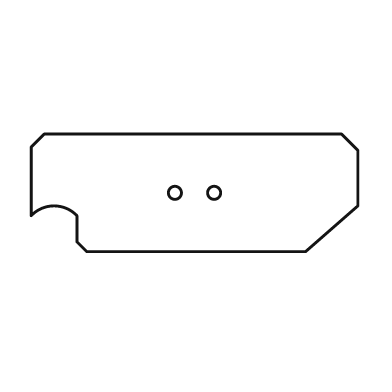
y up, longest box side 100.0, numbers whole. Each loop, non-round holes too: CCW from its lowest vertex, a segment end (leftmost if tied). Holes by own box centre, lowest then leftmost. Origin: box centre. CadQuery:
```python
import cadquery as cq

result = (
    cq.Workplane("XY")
    .moveTo(-33.0, -18.0)
    .lineTo(34.0, -18.0)
    .lineTo(50.0, -4.0)
    .lineTo(50.0, 13.0)
    .lineTo(45.0, 18.0)
    .lineTo(-46.0, 18.0)
    .lineTo(-50.0, 14.0)
    .lineTo(-50.0, -7.0)
    .threePointArc((-43.0, -4.0), (-36.0, -7.0))
    .lineTo(-36.0, -15.0)
    .close()
    .moveTo(-6.0, 0.0)
    .circle(2.0)
    .moveTo(6.0, 0.0)
    .circle(2.0)
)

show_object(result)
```